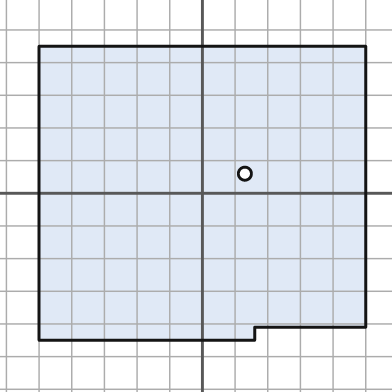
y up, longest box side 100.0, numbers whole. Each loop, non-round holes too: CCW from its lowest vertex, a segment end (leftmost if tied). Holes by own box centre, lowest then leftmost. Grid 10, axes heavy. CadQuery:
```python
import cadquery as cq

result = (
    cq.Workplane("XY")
    .moveTo(-50.0, -45.0)
    .lineTo(16.0, -45.0)
    .lineTo(16.0, -41.0)
    .lineTo(50.0, -41.0)
    .lineTo(50.0, 45.0)
    .lineTo(-50.0, 45.0)
    .close()
    .moveTo(13.0, 6.0)
    .circle(2.0)
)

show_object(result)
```